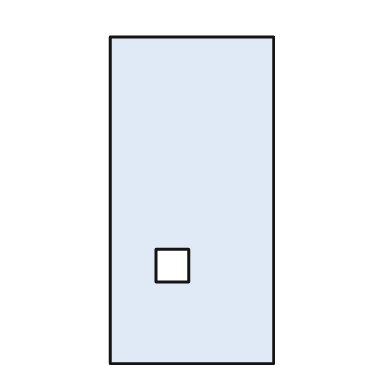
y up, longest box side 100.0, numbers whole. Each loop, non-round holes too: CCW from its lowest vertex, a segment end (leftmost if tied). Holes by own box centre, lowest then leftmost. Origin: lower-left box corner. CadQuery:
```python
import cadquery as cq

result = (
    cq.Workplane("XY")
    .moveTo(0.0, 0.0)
    .lineTo(50.0, 0.0)
    .lineTo(50.0, 100.0)
    .lineTo(0.0, 100.0)
    .close()
    .moveTo(14.0, 25.0)
    .lineTo(24.0, 25.0)
    .lineTo(24.0, 35.0)
    .lineTo(14.0, 35.0)
    .close()
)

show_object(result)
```